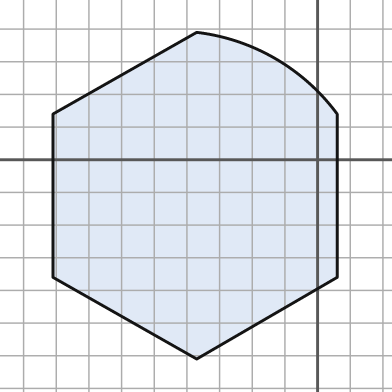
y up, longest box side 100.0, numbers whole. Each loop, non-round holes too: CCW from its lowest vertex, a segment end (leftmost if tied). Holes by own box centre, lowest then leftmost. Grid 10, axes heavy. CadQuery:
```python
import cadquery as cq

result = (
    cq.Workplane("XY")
    .moveTo(-37.0, -61.0)
    .lineTo(6.0, -36.0)
    .lineTo(6.0, 14.0)
    .threePointArc((-13.0, 31.0), (-37.0, 39.0))
    .lineTo(-81.0, 14.0)
    .lineTo(-81.0, -36.0)
    .close()
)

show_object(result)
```